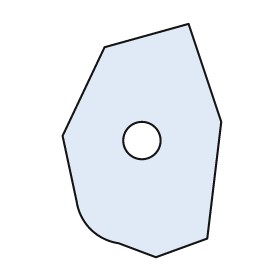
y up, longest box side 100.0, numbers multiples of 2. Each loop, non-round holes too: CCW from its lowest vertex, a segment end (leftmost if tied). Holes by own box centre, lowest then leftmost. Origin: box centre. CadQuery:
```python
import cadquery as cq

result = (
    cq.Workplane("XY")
    .moveTo(6.0, -50.0)
    .lineTo(28.0, -42.0)
    .lineTo(34.0, 8.0)
    .lineTo(20.0, 50.0)
    .lineTo(-16.0, 40.0)
    .lineTo(-34.0, 2.0)
    .lineTo(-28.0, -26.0)
    .threePointArc((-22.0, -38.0), (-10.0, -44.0))
    .close()
    .moveTo(0.0, 0.0)
    .circle(8.0)
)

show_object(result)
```